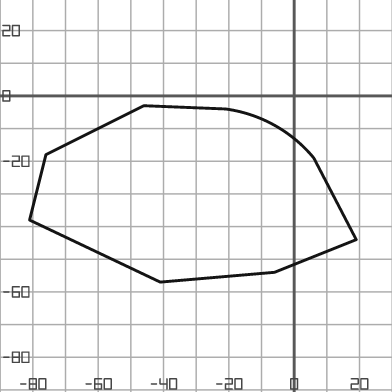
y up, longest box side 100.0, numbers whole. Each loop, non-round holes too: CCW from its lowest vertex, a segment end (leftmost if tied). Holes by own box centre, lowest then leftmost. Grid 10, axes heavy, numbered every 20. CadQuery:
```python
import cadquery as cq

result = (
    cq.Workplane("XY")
    .moveTo(-41.0, -57.0)
    .lineTo(-6.0, -54.0)
    .lineTo(19.0, -44.0)
    .lineTo(6.0, -19.0)
    .threePointArc((-6.0, -9.0), (-21.0, -4.0))
    .lineTo(-46.0, -3.0)
    .lineTo(-76.0, -18.0)
    .lineTo(-81.0, -38.0)
    .close()
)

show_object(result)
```